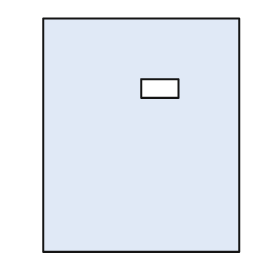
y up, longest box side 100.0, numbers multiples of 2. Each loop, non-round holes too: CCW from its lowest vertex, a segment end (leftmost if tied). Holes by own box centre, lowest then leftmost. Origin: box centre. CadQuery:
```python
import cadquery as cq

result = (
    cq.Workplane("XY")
    .moveTo(-42.0, -50.0)
    .lineTo(42.0, -50.0)
    .lineTo(42.0, 50.0)
    .lineTo(-42.0, 50.0)
    .close()
    .moveTo(0.0, 16.0)
    .lineTo(16.0, 16.0)
    .lineTo(16.0, 24.0)
    .lineTo(0.0, 24.0)
    .close()
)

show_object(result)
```